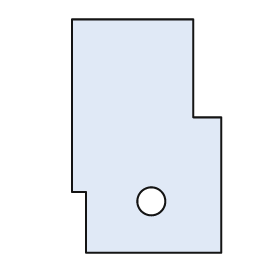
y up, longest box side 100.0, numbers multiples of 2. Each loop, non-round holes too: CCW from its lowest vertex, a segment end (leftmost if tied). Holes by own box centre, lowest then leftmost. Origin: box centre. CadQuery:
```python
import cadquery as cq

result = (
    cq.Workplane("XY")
    .moveTo(-26.0, -50.0)
    .lineTo(32.0, -50.0)
    .lineTo(32.0, 8.0)
    .lineTo(20.0, 8.0)
    .lineTo(20.0, 50.0)
    .lineTo(-32.0, 50.0)
    .lineTo(-32.0, -24.0)
    .lineTo(-26.0, -24.0)
    .close()
    .moveTo(2.0, -28.0)
    .circle(6.0)
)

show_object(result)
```